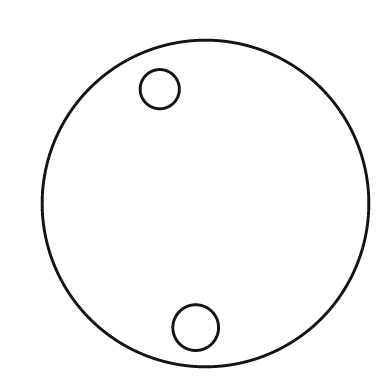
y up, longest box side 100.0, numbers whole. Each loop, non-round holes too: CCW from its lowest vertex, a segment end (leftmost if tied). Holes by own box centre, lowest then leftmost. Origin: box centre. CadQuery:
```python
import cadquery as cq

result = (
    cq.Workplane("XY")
    .moveTo(0.0, 0.0)
    .circle(50.0)
    .moveTo(-3.0, -38.0)
    .circle(7.0)
    .moveTo(-14.0, 35.0)
    .circle(6.0)
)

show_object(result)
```